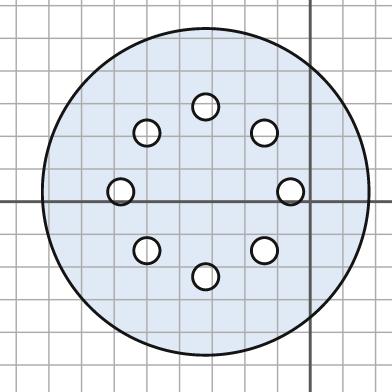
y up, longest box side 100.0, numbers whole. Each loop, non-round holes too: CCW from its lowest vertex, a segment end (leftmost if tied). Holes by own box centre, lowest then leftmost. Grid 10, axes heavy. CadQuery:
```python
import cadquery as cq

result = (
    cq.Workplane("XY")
    .moveTo(-32.0, 3.0)
    .circle(50.0)
    .moveTo(-32.0, -23.0)
    .circle(4.0)
    .moveTo(-50.0, -15.0)
    .circle(4.0)
    .moveTo(-14.0, -15.0)
    .circle(4.0)
    .moveTo(-58.0, 3.0)
    .circle(4.0)
    .moveTo(-6.0, 3.0)
    .circle(4.0)
    .moveTo(-50.0, 21.0)
    .circle(4.0)
    .moveTo(-14.0, 21.0)
    .circle(4.0)
    .moveTo(-32.0, 29.0)
    .circle(4.0)
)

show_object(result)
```